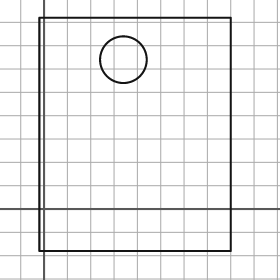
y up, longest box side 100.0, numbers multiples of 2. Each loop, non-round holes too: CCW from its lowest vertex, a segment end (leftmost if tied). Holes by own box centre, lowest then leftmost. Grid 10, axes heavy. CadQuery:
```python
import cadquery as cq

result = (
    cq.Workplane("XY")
    .moveTo(-2.0, -18.0)
    .lineTo(80.0, -18.0)
    .lineTo(80.0, 82.0)
    .lineTo(-2.0, 82.0)
    .close()
    .moveTo(34.0, 64.0)
    .circle(10.0)
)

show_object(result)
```